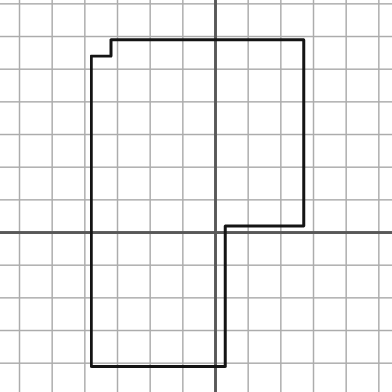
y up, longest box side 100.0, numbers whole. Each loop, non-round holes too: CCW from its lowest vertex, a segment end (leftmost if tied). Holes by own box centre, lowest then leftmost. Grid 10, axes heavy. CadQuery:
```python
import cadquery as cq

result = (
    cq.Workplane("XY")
    .moveTo(-38.0, -41.0)
    .lineTo(3.0, -41.0)
    .lineTo(3.0, 2.0)
    .lineTo(27.0, 2.0)
    .lineTo(27.0, 59.0)
    .lineTo(-32.0, 59.0)
    .lineTo(-32.0, 54.0)
    .lineTo(-38.0, 54.0)
    .close()
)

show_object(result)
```